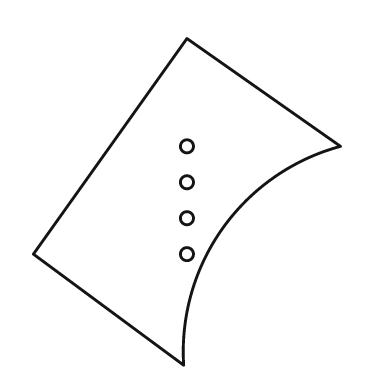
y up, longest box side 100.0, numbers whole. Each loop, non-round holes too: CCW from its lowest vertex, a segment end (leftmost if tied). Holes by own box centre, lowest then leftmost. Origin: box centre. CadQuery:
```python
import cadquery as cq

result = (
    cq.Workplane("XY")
    .moveTo(-1.0, -50.0)
    .threePointArc((11.0, -8.0), (47.0, 17.0))
    .lineTo(0.0, 50.0)
    .lineTo(-47.0, -16.0)
    .close()
    .moveTo(0.0, -16.0)
    .circle(2.0)
    .moveTo(0.0, -5.0)
    .circle(2.0)
    .moveTo(0.0, 6.0)
    .circle(2.0)
    .moveTo(0.0, 17.0)
    .circle(2.0)
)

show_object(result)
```